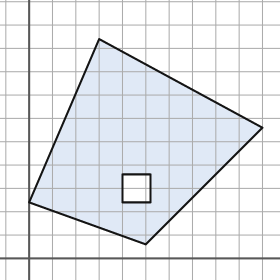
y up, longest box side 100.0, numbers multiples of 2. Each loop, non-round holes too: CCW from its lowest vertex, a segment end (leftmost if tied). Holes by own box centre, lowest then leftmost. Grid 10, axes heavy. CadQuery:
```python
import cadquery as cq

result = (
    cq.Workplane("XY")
    .moveTo(50.0, 6.0)
    .lineTo(100.0, 56.0)
    .lineTo(30.0, 94.0)
    .lineTo(0.0, 24.0)
    .close()
    .moveTo(40.0, 24.0)
    .lineTo(52.0, 24.0)
    .lineTo(52.0, 36.0)
    .lineTo(40.0, 36.0)
    .close()
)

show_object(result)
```